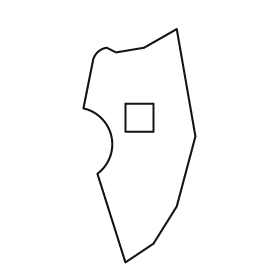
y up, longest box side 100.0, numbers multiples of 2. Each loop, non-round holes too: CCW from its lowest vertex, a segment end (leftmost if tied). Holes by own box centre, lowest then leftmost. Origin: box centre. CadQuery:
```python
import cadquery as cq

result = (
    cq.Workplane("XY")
    .moveTo(-6.0, -50.0)
    .lineTo(6.0, -42.0)
    .lineTo(16.0, -26.0)
    .lineTo(24.0, 4.0)
    .lineTo(16.0, 50.0)
    .lineTo(2.0, 42.0)
    .lineTo(-10.0, 40.0)
    .lineTo(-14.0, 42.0)
    .threePointArc((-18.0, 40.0), (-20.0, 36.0))
    .lineTo(-24.0, 16.0)
    .threePointArc((-12.0, 4.0), (-18.0, -12.0))
    .close()
    .moveTo(-6.0, 6.0)
    .lineTo(6.0, 6.0)
    .lineTo(6.0, 18.0)
    .lineTo(-6.0, 18.0)
    .close()
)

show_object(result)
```